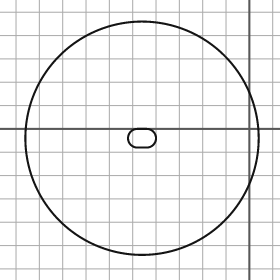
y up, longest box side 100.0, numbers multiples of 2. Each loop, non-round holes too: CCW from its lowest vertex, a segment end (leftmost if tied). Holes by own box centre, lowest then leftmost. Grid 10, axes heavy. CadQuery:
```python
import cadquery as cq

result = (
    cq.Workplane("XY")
    .moveTo(-46.0, -4.0)
    .circle(50.0)
    .moveTo(-48.0, -8.0)
    .lineTo(-44.0, -8.0)
    .threePointArc((-40.0, -4.0), (-44.0, 0.0))
    .lineTo(-48.0, 0.0)
    .threePointArc((-52.0, -4.0), (-48.0, -8.0))
    .close()
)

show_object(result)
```